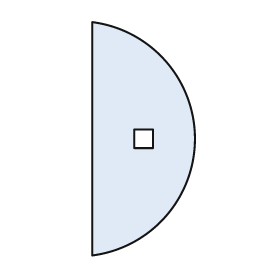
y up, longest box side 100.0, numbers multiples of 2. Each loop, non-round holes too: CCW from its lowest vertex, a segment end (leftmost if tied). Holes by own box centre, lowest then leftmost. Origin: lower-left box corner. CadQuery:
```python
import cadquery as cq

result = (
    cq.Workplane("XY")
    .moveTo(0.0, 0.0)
    .threePointArc((44.0, 50.0), (0.0, 100.0))
    .close()
    .moveTo(18.0, 46.0)
    .lineTo(26.0, 46.0)
    .lineTo(26.0, 54.0)
    .lineTo(18.0, 54.0)
    .close()
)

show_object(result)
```